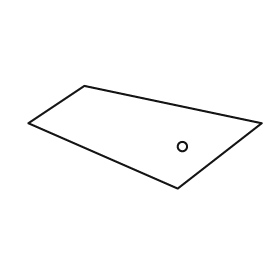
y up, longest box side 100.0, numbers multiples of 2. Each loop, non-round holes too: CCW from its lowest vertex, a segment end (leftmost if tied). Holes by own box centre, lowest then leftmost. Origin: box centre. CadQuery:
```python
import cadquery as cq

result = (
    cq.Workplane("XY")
    .moveTo(14.0, -22.0)
    .lineTo(50.0, 6.0)
    .lineTo(-26.0, 22.0)
    .lineTo(-50.0, 6.0)
    .close()
    .moveTo(16.0, -4.0)
    .circle(2.0)
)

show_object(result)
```